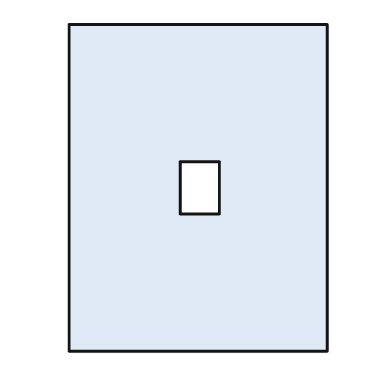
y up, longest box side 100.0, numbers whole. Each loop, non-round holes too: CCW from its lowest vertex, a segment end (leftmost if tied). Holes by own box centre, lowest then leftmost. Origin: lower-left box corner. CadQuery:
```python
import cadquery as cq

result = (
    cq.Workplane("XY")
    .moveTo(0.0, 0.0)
    .lineTo(79.0, 0.0)
    .lineTo(79.0, 100.0)
    .lineTo(0.0, 100.0)
    .close()
    .moveTo(34.0, 42.0)
    .lineTo(46.0, 42.0)
    .lineTo(46.0, 58.0)
    .lineTo(34.0, 58.0)
    .close()
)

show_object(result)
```